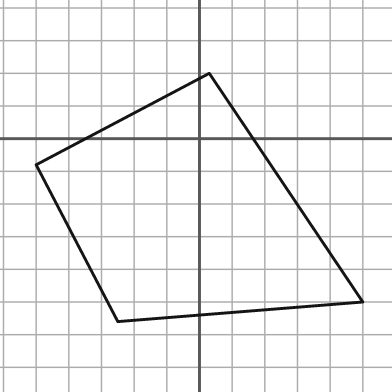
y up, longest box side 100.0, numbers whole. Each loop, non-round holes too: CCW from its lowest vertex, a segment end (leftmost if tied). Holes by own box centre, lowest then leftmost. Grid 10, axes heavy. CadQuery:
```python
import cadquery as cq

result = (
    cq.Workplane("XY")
    .moveTo(-25.0, -56.0)
    .lineTo(50.0, -50.0)
    .lineTo(3.0, 20.0)
    .lineTo(-50.0, -8.0)
    .close()
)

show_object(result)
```